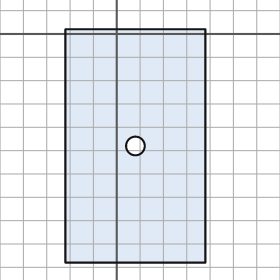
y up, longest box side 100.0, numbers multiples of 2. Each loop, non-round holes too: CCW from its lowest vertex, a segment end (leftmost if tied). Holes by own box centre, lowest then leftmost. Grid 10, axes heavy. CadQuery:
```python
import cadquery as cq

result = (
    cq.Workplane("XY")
    .moveTo(-22.0, -98.0)
    .lineTo(38.0, -98.0)
    .lineTo(38.0, 2.0)
    .lineTo(-22.0, 2.0)
    .close()
    .moveTo(8.0, -48.0)
    .circle(4.0)
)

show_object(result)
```